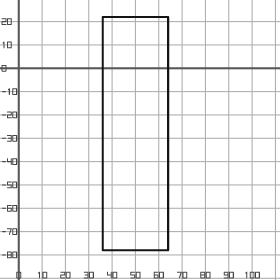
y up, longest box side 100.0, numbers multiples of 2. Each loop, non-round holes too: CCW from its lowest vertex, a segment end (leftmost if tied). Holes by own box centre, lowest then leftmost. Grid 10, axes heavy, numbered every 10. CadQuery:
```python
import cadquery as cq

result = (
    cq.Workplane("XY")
    .moveTo(36.0, -78.0)
    .lineTo(64.0, -78.0)
    .lineTo(64.0, 22.0)
    .lineTo(36.0, 22.0)
    .close()
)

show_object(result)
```